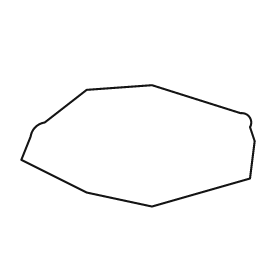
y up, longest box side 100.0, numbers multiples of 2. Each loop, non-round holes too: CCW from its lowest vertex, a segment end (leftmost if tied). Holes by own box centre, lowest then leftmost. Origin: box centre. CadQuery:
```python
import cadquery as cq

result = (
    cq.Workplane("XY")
    .moveTo(6.0, -26.0)
    .lineTo(48.0, -14.0)
    .lineTo(50.0, 2.0)
    .lineTo(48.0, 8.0)
    .threePointArc((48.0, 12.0), (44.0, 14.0))
    .lineTo(6.0, 26.0)
    .lineTo(-22.0, 24.0)
    .lineTo(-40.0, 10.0)
    .threePointArc((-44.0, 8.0), (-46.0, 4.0))
    .lineTo(-50.0, -6.0)
    .lineTo(-22.0, -20.0)
    .close()
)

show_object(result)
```